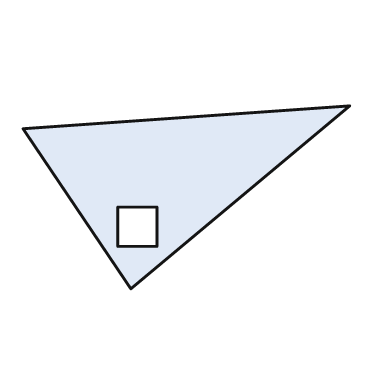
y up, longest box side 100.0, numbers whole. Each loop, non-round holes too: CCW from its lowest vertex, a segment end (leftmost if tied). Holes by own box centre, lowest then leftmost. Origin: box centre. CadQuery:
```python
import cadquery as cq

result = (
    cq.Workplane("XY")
    .moveTo(-17.0, -28.0)
    .lineTo(50.0, 28.0)
    .lineTo(-50.0, 21.0)
    .close()
    .moveTo(-21.0, -15.0)
    .lineTo(-9.0, -15.0)
    .lineTo(-9.0, -3.0)
    .lineTo(-21.0, -3.0)
    .close()
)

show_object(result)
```